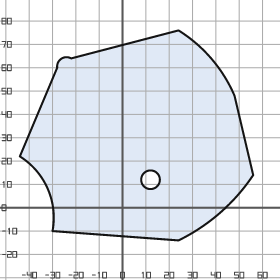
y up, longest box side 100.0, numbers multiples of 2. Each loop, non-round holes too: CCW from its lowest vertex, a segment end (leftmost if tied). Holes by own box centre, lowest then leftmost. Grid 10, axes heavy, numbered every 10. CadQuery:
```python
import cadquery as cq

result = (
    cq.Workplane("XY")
    .moveTo(24.0, -14.0)
    .threePointArc((42.0, -2.0), (56.0, 14.0))
    .lineTo(48.0, 48.0)
    .threePointArc((38.0, 64.0), (24.0, 76.0))
    .lineTo(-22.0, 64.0)
    .threePointArc((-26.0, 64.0), (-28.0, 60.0))
    .lineTo(-44.0, 22.0)
    .threePointArc((-32.0, 8.0), (-30.0, -10.0))
    .close()
    .moveTo(12.0, 12.0)
    .circle(4.0)
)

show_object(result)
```